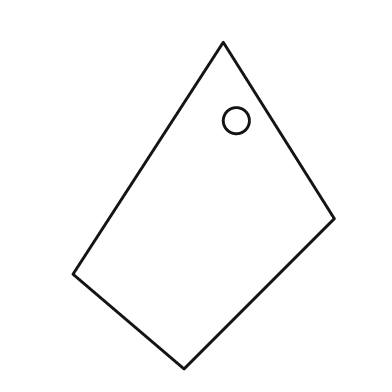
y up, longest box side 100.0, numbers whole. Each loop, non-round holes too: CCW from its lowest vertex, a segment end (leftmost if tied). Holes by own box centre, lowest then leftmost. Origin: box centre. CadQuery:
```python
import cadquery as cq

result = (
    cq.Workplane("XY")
    .moveTo(-6.0, -50.0)
    .lineTo(40.0, -4.0)
    .lineTo(6.0, 50.0)
    .lineTo(-40.0, -21.0)
    .close()
    .moveTo(10.0, 26.0)
    .circle(4.0)
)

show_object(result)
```